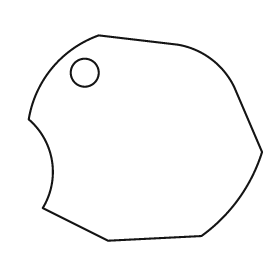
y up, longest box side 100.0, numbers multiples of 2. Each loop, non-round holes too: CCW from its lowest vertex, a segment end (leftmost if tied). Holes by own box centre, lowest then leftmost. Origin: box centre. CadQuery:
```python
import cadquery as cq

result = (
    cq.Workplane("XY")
    .moveTo(-16.0, -44.0)
    .lineTo(24.0, -42.0)
    .threePointArc((40.0, -26.0), (50.0, -6.0))
    .lineTo(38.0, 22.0)
    .threePointArc((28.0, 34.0), (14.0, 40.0))
    .lineTo(-20.0, 44.0)
    .threePointArc((-40.0, 30.0), (-50.0, 8.0))
    .threePointArc((-40.0, -10.0), (-44.0, -30.0))
    .close()
    .moveTo(-26.0, 28.0)
    .circle(6.0)
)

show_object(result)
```